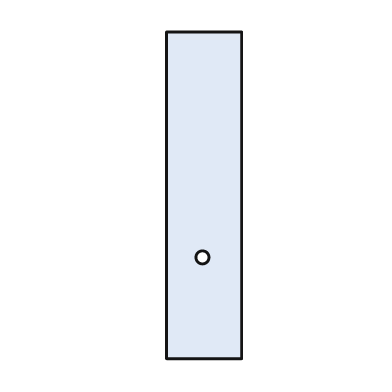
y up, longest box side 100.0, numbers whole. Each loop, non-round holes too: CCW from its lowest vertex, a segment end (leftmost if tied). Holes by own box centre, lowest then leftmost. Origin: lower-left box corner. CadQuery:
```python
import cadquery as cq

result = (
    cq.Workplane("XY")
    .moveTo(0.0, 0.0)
    .lineTo(23.0, 0.0)
    .lineTo(23.0, 100.0)
    .lineTo(0.0, 100.0)
    .close()
    .moveTo(11.0, 31.0)
    .circle(2.0)
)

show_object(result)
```